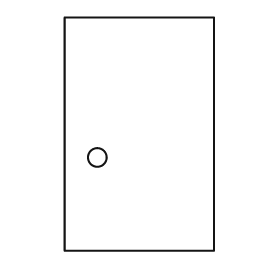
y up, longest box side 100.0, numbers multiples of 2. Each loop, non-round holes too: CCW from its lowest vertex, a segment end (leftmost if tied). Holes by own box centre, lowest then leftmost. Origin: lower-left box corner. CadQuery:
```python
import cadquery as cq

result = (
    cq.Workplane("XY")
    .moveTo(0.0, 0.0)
    .lineTo(64.0, 0.0)
    .lineTo(64.0, 100.0)
    .lineTo(0.0, 100.0)
    .close()
    .moveTo(14.0, 40.0)
    .circle(4.0)
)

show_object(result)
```